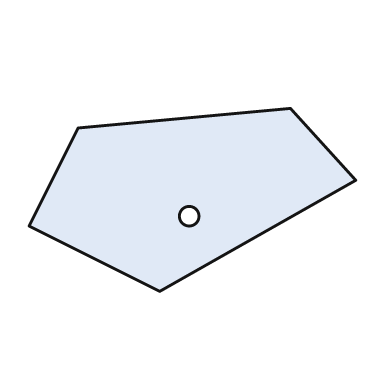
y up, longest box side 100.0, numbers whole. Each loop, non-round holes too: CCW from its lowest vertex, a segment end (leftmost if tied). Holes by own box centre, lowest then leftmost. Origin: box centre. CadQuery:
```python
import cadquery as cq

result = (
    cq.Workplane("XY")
    .moveTo(-10.0, -28.0)
    .lineTo(50.0, 6.0)
    .lineTo(30.0, 28.0)
    .lineTo(-35.0, 22.0)
    .lineTo(-50.0, -8.0)
    .close()
    .moveTo(-1.0, -5.0)
    .circle(3.0)
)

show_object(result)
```